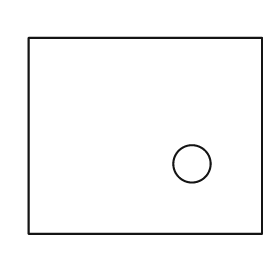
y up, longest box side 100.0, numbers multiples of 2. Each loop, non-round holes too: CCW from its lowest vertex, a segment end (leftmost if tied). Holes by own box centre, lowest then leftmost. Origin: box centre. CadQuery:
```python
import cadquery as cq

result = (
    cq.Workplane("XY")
    .moveTo(-50.0, -42.0)
    .lineTo(50.0, -42.0)
    .lineTo(50.0, 42.0)
    .lineTo(-50.0, 42.0)
    .close()
    .moveTo(20.0, -12.0)
    .circle(8.0)
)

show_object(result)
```